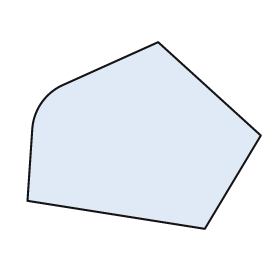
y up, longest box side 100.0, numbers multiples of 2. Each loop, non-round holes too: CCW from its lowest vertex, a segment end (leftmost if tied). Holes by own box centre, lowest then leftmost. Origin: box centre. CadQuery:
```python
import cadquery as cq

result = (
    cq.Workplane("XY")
    .moveTo(26.0, -40.0)
    .lineTo(50.0, 0.0)
    .lineTo(6.0, 40.0)
    .lineTo(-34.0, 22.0)
    .threePointArc((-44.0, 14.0), (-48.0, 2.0))
    .lineTo(-50.0, -28.0)
    .close()
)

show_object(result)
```